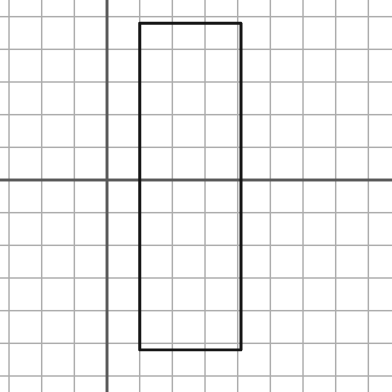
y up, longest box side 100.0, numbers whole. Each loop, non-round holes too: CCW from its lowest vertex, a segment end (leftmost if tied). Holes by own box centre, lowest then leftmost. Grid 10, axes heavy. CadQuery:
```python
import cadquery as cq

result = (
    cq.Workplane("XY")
    .moveTo(10.0, -52.0)
    .lineTo(41.0, -52.0)
    .lineTo(41.0, 48.0)
    .lineTo(10.0, 48.0)
    .close()
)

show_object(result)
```